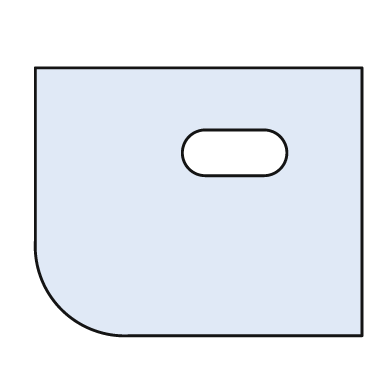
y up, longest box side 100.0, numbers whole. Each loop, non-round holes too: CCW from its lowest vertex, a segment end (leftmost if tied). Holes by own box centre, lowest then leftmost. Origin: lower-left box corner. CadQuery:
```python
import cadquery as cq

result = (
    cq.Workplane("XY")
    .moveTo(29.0, 0.0)
    .lineTo(100.0, 0.0)
    .lineTo(100.0, 82.0)
    .lineTo(0.0, 82.0)
    .lineTo(0.0, 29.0)
    .threePointArc((8.0, 8.0), (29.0, 0.0))
    .close()
    .moveTo(52.0, 49.0)
    .lineTo(70.0, 49.0)
    .threePointArc((77.0, 56.0), (70.0, 63.0))
    .lineTo(52.0, 63.0)
    .threePointArc((45.0, 56.0), (52.0, 49.0))
    .close()
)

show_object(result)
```